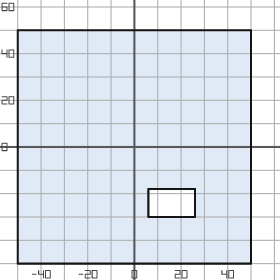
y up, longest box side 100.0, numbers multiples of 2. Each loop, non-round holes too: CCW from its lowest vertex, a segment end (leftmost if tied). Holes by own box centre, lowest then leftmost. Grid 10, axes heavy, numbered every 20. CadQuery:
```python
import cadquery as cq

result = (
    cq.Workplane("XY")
    .moveTo(-50.0, -50.0)
    .lineTo(50.0, -50.0)
    .lineTo(50.0, 50.0)
    .lineTo(-50.0, 50.0)
    .close()
    .moveTo(6.0, -30.0)
    .lineTo(26.0, -30.0)
    .lineTo(26.0, -18.0)
    .lineTo(6.0, -18.0)
    .close()
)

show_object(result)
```